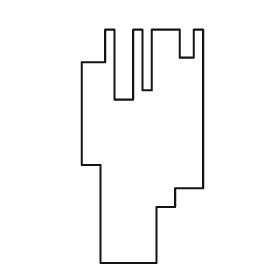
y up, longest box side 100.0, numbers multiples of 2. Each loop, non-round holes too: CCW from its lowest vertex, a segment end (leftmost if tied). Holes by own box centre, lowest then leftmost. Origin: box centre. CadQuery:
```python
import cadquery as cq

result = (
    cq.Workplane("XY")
    .moveTo(-18.0, -50.0)
    .lineTo(6.0, -50.0)
    .lineTo(6.0, -26.0)
    .lineTo(14.0, -26.0)
    .lineTo(14.0, -18.0)
    .lineTo(26.0, -18.0)
    .lineTo(26.0, 50.0)
    .lineTo(22.0, 50.0)
    .lineTo(22.0, 38.0)
    .lineTo(16.0, 38.0)
    .lineTo(16.0, 50.0)
    .lineTo(4.0, 50.0)
    .lineTo(4.0, 24.0)
    .lineTo(0.0, 24.0)
    .lineTo(0.0, 50.0)
    .lineTo(-4.0, 50.0)
    .lineTo(-4.0, 20.0)
    .lineTo(-12.0, 20.0)
    .lineTo(-12.0, 50.0)
    .lineTo(-16.0, 50.0)
    .lineTo(-16.0, 36.0)
    .lineTo(-26.0, 36.0)
    .lineTo(-26.0, -8.0)
    .lineTo(-18.0, -8.0)
    .close()
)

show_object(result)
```